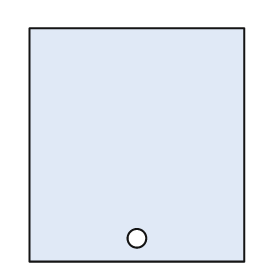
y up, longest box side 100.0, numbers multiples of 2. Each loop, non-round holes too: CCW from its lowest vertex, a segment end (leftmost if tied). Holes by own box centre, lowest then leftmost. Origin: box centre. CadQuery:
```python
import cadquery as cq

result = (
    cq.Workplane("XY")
    .moveTo(-46.0, -50.0)
    .lineTo(46.0, -50.0)
    .lineTo(46.0, 50.0)
    .lineTo(-46.0, 50.0)
    .close()
    .moveTo(0.0, -40.0)
    .circle(4.0)
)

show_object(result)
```